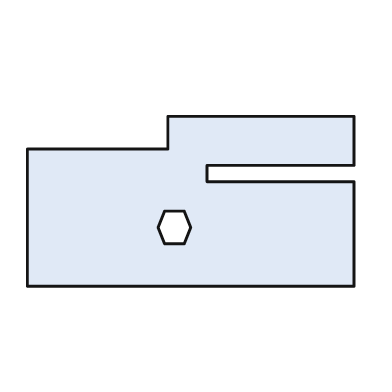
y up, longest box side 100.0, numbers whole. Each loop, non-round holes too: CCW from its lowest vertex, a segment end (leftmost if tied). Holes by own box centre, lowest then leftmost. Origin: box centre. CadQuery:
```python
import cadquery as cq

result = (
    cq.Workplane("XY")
    .moveTo(-50.0, -26.0)
    .lineTo(50.0, -26.0)
    .lineTo(50.0, 6.0)
    .lineTo(5.0, 6.0)
    .lineTo(5.0, 11.0)
    .lineTo(50.0, 11.0)
    .lineTo(50.0, 26.0)
    .lineTo(-7.0, 26.0)
    .lineTo(-7.0, 16.0)
    .lineTo(-50.0, 16.0)
    .close()
    .moveTo(-8.0, -13.0)
    .lineTo(-2.0, -13.0)
    .lineTo(0.0, -8.0)
    .lineTo(-2.0, -3.0)
    .lineTo(-8.0, -3.0)
    .lineTo(-10.0, -8.0)
    .close()
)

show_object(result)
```